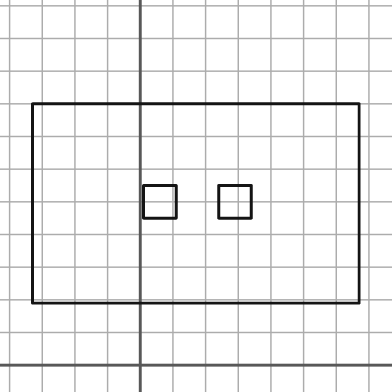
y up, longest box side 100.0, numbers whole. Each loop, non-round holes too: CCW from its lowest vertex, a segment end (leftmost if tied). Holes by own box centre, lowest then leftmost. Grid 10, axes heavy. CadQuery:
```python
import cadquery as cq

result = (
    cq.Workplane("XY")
    .moveTo(-33.0, 19.0)
    .lineTo(67.0, 19.0)
    .lineTo(67.0, 80.0)
    .lineTo(-33.0, 80.0)
    .close()
    .moveTo(1.0, 45.0)
    .lineTo(11.0, 45.0)
    .lineTo(11.0, 55.0)
    .lineTo(1.0, 55.0)
    .close()
    .moveTo(24.0, 45.0)
    .lineTo(34.0, 45.0)
    .lineTo(34.0, 55.0)
    .lineTo(24.0, 55.0)
    .close()
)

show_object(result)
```